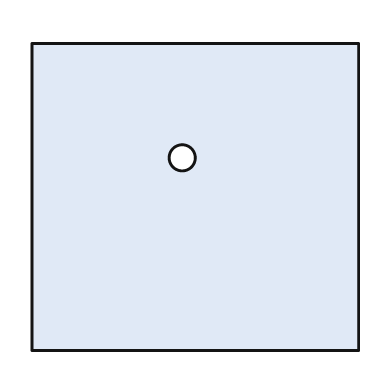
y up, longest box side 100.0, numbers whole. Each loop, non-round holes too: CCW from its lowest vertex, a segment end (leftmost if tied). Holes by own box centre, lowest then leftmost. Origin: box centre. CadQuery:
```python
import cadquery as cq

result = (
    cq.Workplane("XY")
    .moveTo(-50.0, -47.0)
    .lineTo(50.0, -47.0)
    .lineTo(50.0, 47.0)
    .lineTo(-50.0, 47.0)
    .close()
    .moveTo(-4.0, 12.0)
    .circle(4.0)
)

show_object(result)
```